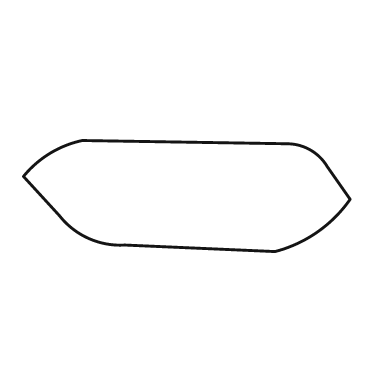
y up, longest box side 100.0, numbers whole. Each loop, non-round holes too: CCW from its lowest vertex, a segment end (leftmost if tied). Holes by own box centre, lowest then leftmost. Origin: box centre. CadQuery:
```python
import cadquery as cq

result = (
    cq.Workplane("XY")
    .moveTo(27.0, -17.0)
    .threePointArc((40.0, -11.0), (50.0, -1.0))
    .lineTo(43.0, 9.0)
    .threePointArc((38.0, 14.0), (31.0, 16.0))
    .lineTo(-32.0, 17.0)
    .threePointArc((-42.0, 13.0), (-50.0, 6.0))
    .lineTo(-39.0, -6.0)
    .threePointArc((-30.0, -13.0), (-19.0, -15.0))
    .close()
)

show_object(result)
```